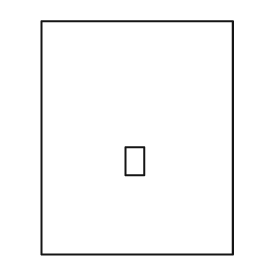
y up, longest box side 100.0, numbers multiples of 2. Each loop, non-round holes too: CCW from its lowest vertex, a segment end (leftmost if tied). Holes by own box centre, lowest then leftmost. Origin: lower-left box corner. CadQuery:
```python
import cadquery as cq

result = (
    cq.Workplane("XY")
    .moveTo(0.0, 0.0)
    .lineTo(82.0, 0.0)
    .lineTo(82.0, 100.0)
    .lineTo(0.0, 100.0)
    .close()
    .moveTo(36.0, 34.0)
    .lineTo(44.0, 34.0)
    .lineTo(44.0, 46.0)
    .lineTo(36.0, 46.0)
    .close()
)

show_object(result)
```